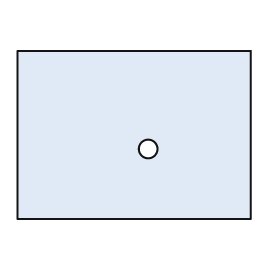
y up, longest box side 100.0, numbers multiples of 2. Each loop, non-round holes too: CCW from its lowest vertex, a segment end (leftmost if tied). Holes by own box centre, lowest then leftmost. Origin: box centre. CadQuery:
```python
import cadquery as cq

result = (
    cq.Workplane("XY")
    .moveTo(-50.0, -36.0)
    .lineTo(50.0, -36.0)
    .lineTo(50.0, 36.0)
    .lineTo(-50.0, 36.0)
    .close()
    .moveTo(6.0, -6.0)
    .circle(4.0)
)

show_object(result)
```